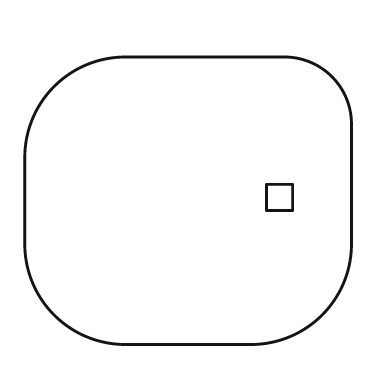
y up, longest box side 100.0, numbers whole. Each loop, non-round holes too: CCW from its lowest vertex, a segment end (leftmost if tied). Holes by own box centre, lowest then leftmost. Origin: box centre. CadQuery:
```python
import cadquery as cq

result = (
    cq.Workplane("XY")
    .moveTo(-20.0, -44.0)
    .lineTo(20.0, -44.0)
    .threePointArc((41.0, -35.0), (50.0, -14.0))
    .lineTo(50.0, 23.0)
    .threePointArc((44.0, 38.0), (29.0, 44.0))
    .lineTo(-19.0, 44.0)
    .threePointArc((-41.0, 35.0), (-50.0, 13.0))
    .lineTo(-50.0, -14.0)
    .threePointArc((-41.0, -35.0), (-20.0, -44.0))
    .close()
    .moveTo(24.0, -3.0)
    .lineTo(32.0, -3.0)
    .lineTo(32.0, 5.0)
    .lineTo(24.0, 5.0)
    .close()
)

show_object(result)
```